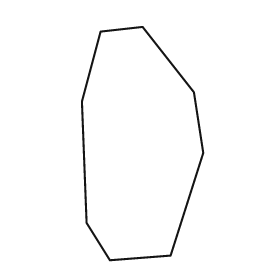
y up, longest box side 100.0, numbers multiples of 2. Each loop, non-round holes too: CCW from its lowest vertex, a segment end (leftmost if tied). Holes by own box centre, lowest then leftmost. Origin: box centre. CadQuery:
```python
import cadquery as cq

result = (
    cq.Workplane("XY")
    .moveTo(-14.0, -50.0)
    .lineTo(12.0, -48.0)
    .lineTo(26.0, -4.0)
    .lineTo(22.0, 22.0)
    .lineTo(0.0, 50.0)
    .lineTo(-18.0, 48.0)
    .lineTo(-26.0, 18.0)
    .lineTo(-24.0, -34.0)
    .close()
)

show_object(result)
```